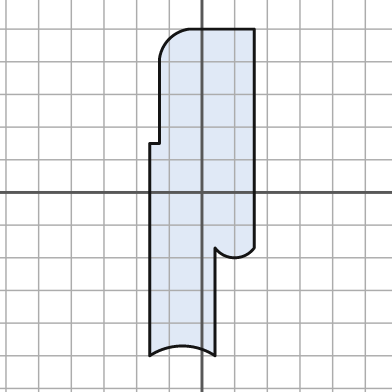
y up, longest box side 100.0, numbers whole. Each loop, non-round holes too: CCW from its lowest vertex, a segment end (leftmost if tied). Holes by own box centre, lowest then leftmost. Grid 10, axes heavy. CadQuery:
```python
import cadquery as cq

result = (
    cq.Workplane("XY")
    .moveTo(-16.0, -50.0)
    .threePointArc((-6.0, -47.0), (4.0, -50.0))
    .lineTo(4.0, -17.0)
    .threePointArc((10.0, -20.0), (16.0, -17.0))
    .lineTo(16.0, 50.0)
    .lineTo(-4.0, 50.0)
    .threePointArc((-10.0, 47.0), (-13.0, 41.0))
    .lineTo(-13.0, 15.0)
    .lineTo(-16.0, 15.0)
    .close()
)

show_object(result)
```